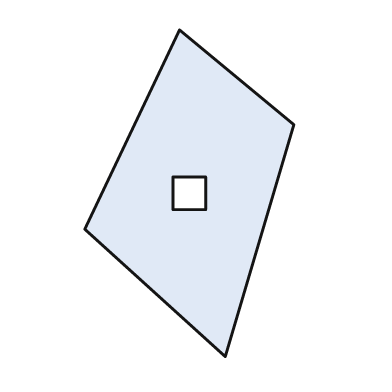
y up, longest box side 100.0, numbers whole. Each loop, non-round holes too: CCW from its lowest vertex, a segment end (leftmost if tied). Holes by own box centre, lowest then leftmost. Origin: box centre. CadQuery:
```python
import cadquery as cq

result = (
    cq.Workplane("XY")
    .moveTo(11.0, -50.0)
    .lineTo(32.0, 21.0)
    .lineTo(-3.0, 50.0)
    .lineTo(-32.0, -11.0)
    .close()
    .moveTo(-5.0, -5.0)
    .lineTo(5.0, -5.0)
    .lineTo(5.0, 5.0)
    .lineTo(-5.0, 5.0)
    .close()
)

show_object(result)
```